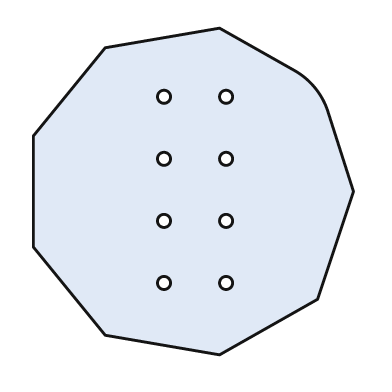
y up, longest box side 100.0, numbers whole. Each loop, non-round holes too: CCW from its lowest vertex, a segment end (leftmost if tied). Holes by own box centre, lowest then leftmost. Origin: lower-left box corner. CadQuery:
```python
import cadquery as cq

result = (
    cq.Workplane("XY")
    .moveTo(57.0, 0.0)
    .lineTo(87.0, 17.0)
    .lineTo(98.0, 50.0)
    .lineTo(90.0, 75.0)
    .threePointArc((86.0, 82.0), (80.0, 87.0))
    .lineTo(57.0, 100.0)
    .lineTo(22.0, 94.0)
    .lineTo(0.0, 67.0)
    .lineTo(0.0, 33.0)
    .lineTo(22.0, 6.0)
    .close()
    .moveTo(40.0, 22.0)
    .circle(2.0)
    .moveTo(59.0, 22.0)
    .circle(2.0)
    .moveTo(40.0, 41.0)
    .circle(2.0)
    .moveTo(59.0, 41.0)
    .circle(2.0)
    .moveTo(40.0, 60.0)
    .circle(2.0)
    .moveTo(59.0, 60.0)
    .circle(2.0)
    .moveTo(40.0, 79.0)
    .circle(2.0)
    .moveTo(59.0, 79.0)
    .circle(2.0)
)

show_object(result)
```